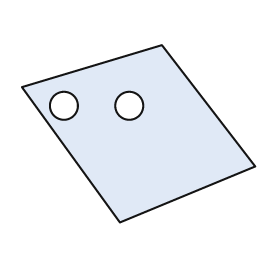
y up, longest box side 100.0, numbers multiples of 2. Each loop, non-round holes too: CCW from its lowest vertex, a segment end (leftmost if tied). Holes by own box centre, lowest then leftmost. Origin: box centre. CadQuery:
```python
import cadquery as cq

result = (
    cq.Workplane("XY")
    .moveTo(-8.0, -38.0)
    .lineTo(50.0, -14.0)
    .lineTo(10.0, 38.0)
    .lineTo(-50.0, 20.0)
    .close()
    .moveTo(-32.0, 12.0)
    .circle(6.0)
    .moveTo(-4.0, 12.0)
    .circle(6.0)
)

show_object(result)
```